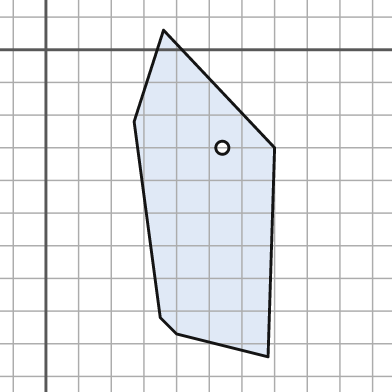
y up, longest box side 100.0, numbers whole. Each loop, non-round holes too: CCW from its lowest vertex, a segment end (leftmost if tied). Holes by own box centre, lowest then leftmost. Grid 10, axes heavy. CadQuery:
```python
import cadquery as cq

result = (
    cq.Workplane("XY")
    .moveTo(68.0, -94.0)
    .lineTo(70.0, -30.0)
    .lineTo(36.0, 6.0)
    .lineTo(27.0, -22.0)
    .lineTo(35.0, -82.0)
    .lineTo(40.0, -87.0)
    .close()
    .moveTo(54.0, -30.0)
    .circle(2.0)
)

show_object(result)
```